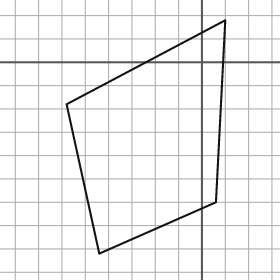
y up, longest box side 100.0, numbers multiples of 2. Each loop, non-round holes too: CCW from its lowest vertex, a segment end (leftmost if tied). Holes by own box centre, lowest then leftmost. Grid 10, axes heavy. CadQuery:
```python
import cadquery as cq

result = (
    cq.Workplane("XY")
    .moveTo(-44.0, -82.0)
    .lineTo(6.0, -60.0)
    .lineTo(10.0, 18.0)
    .lineTo(-58.0, -18.0)
    .close()
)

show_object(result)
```